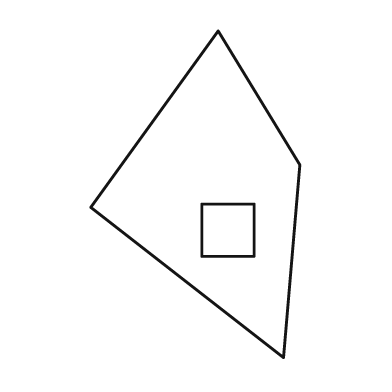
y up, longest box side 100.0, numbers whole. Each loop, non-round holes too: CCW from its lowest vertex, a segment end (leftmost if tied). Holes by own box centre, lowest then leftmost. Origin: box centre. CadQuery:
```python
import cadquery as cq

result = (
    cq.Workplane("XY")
    .moveTo(27.0, -50.0)
    .lineTo(32.0, 9.0)
    .lineTo(7.0, 50.0)
    .lineTo(-32.0, -4.0)
    .close()
    .moveTo(2.0, -19.0)
    .lineTo(18.0, -19.0)
    .lineTo(18.0, -3.0)
    .lineTo(2.0, -3.0)
    .close()
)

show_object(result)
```